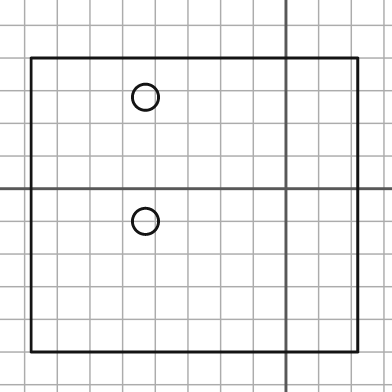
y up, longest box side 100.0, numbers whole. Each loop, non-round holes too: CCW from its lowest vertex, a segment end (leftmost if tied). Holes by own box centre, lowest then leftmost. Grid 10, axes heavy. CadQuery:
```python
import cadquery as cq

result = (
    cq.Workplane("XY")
    .moveTo(-78.0, -50.0)
    .lineTo(22.0, -50.0)
    .lineTo(22.0, 40.0)
    .lineTo(-78.0, 40.0)
    .close()
    .moveTo(-43.0, -10.0)
    .circle(4.0)
    .moveTo(-43.0, 28.0)
    .circle(4.0)
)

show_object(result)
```